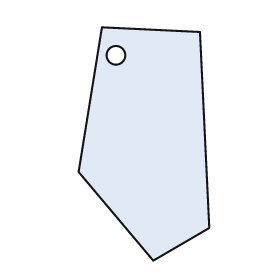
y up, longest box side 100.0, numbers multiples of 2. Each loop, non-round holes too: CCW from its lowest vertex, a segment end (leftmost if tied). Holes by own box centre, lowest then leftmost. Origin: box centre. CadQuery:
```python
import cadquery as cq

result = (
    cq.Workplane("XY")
    .moveTo(4.0, -50.0)
    .lineTo(28.0, -36.0)
    .lineTo(24.0, 48.0)
    .lineTo(-18.0, 50.0)
    .lineTo(-28.0, -12.0)
    .close()
    .moveTo(-12.0, 38.0)
    .circle(4.0)
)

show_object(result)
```